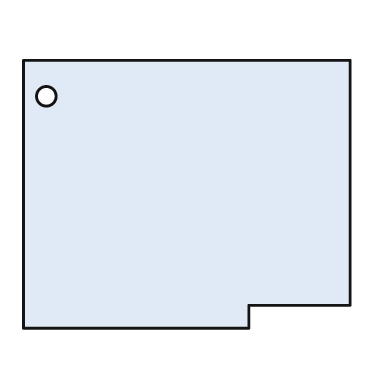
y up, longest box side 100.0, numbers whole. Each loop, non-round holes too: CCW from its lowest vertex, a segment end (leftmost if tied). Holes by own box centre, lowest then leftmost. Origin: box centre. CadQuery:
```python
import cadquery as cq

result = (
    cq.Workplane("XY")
    .moveTo(-50.0, -41.0)
    .lineTo(19.0, -41.0)
    .lineTo(19.0, -34.0)
    .lineTo(50.0, -34.0)
    .lineTo(50.0, 41.0)
    .lineTo(-50.0, 41.0)
    .close()
    .moveTo(-43.0, 30.0)
    .circle(3.0)
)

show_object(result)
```